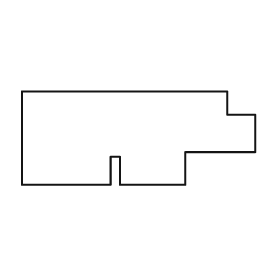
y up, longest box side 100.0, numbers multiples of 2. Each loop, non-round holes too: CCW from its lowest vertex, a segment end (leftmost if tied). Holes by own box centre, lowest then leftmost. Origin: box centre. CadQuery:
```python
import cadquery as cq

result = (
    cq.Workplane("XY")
    .moveTo(-50.0, -20.0)
    .lineTo(-12.0, -20.0)
    .lineTo(-12.0, -8.0)
    .lineTo(-8.0, -8.0)
    .lineTo(-8.0, -20.0)
    .lineTo(20.0, -20.0)
    .lineTo(20.0, -6.0)
    .lineTo(50.0, -6.0)
    .lineTo(50.0, 10.0)
    .lineTo(38.0, 10.0)
    .lineTo(38.0, 20.0)
    .lineTo(-50.0, 20.0)
    .close()
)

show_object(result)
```